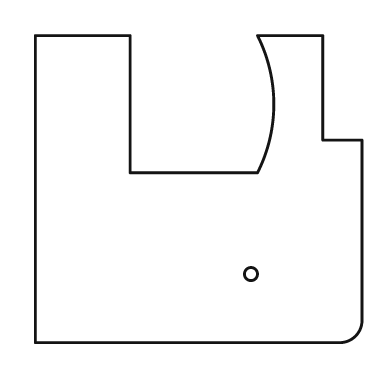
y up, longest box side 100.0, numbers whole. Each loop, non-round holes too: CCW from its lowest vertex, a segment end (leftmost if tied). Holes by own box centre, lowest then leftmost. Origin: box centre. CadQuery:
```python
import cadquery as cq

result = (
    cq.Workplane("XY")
    .moveTo(-50.0, -47.0)
    .lineTo(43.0, -47.0)
    .threePointArc((48.0, -45.0), (50.0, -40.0))
    .lineTo(50.0, 15.0)
    .lineTo(38.0, 15.0)
    .lineTo(38.0, 47.0)
    .lineTo(18.0, 47.0)
    .threePointArc((23.0, 26.0), (18.0, 5.0))
    .lineTo(-21.0, 5.0)
    .lineTo(-21.0, 47.0)
    .lineTo(-50.0, 47.0)
    .close()
    .moveTo(16.0, -26.0)
    .circle(2.0)
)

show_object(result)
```